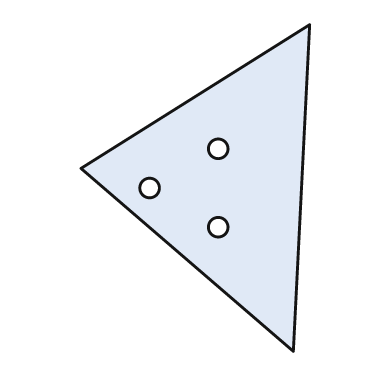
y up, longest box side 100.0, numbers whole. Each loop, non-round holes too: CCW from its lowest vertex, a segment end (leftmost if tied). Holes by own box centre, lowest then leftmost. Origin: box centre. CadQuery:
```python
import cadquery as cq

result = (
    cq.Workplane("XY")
    .moveTo(30.0, -50.0)
    .lineTo(35.0, 50.0)
    .lineTo(-35.0, 6.0)
    .close()
    .moveTo(7.0, -12.0)
    .circle(3.0)
    .moveTo(-14.0, 0.0)
    .circle(3.0)
    .moveTo(7.0, 12.0)
    .circle(3.0)
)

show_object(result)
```